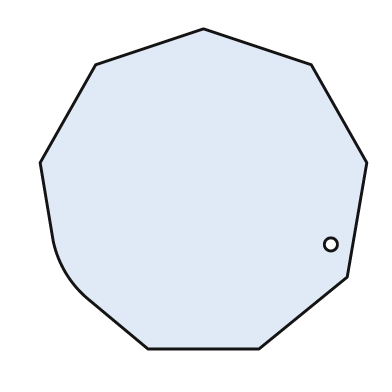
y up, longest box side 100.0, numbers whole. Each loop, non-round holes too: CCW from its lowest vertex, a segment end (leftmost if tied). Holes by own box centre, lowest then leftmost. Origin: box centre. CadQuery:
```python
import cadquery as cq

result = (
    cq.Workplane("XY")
    .moveTo(-17.0, -49.0)
    .lineTo(17.0, -49.0)
    .lineTo(44.0, -27.0)
    .lineTo(50.0, 8.0)
    .lineTo(33.0, 38.0)
    .lineTo(0.0, 49.0)
    .lineTo(-33.0, 38.0)
    .lineTo(-50.0, 8.0)
    .lineTo(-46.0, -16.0)
    .threePointArc((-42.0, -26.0), (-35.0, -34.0))
    .close()
    .moveTo(39.0, -17.0)
    .circle(2.0)
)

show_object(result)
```